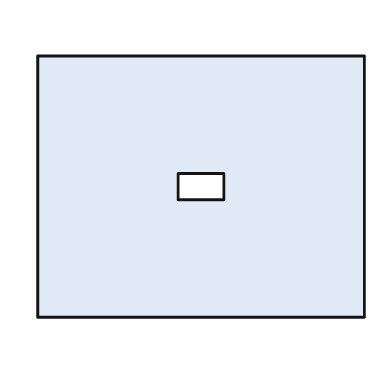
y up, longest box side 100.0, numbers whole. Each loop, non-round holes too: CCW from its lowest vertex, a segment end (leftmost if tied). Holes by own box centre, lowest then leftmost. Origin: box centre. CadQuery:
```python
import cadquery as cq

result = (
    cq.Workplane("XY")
    .moveTo(-50.0, -40.0)
    .lineTo(50.0, -40.0)
    .lineTo(50.0, 40.0)
    .lineTo(-50.0, 40.0)
    .close()
    .moveTo(-7.0, -4.0)
    .lineTo(7.0, -4.0)
    .lineTo(7.0, 4.0)
    .lineTo(-7.0, 4.0)
    .close()
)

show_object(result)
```